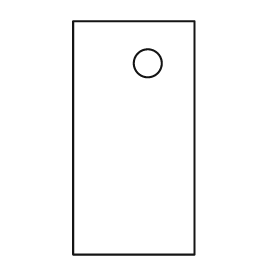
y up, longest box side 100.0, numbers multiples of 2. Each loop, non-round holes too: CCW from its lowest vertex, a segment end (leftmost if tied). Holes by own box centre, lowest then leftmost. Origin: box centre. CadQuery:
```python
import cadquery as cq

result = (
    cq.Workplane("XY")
    .moveTo(-26.0, -50.0)
    .lineTo(26.0, -50.0)
    .lineTo(26.0, 50.0)
    .lineTo(-26.0, 50.0)
    .close()
    .moveTo(6.0, 32.0)
    .circle(6.0)
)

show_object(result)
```